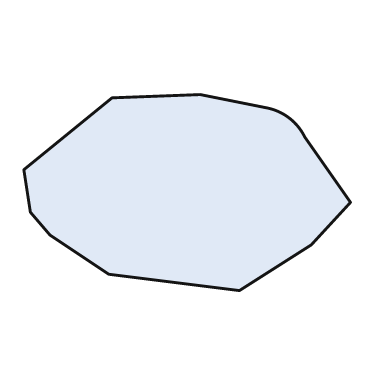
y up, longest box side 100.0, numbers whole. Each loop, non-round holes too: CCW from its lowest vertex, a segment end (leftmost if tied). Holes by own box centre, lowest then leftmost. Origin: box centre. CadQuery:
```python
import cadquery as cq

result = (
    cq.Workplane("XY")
    .moveTo(16.0, -30.0)
    .lineTo(38.0, -16.0)
    .lineTo(50.0, -3.0)
    .lineTo(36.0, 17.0)
    .threePointArc((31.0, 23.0), (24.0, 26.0))
    .lineTo(4.0, 30.0)
    .lineTo(-23.0, 29.0)
    .lineTo(-50.0, 7.0)
    .lineTo(-48.0, -6.0)
    .lineTo(-42.0, -13.0)
    .lineTo(-24.0, -25.0)
    .close()
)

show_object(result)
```